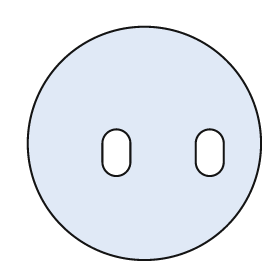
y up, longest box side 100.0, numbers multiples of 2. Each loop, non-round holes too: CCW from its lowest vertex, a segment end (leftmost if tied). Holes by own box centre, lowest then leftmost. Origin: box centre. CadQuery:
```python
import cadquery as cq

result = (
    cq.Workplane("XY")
    .moveTo(0.0, 0.0)
    .circle(50.0)
    .moveTo(-18.0, -8.0)
    .threePointArc((-12.0, -14.0), (-6.0, -8.0))
    .lineTo(-6.0, 0.0)
    .threePointArc((-12.0, 6.0), (-18.0, 0.0))
    .close()
    .moveTo(22.0, -8.0)
    .threePointArc((28.0, -14.0), (34.0, -8.0))
    .lineTo(34.0, 0.0)
    .threePointArc((28.0, 6.0), (22.0, 0.0))
    .close()
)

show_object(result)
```